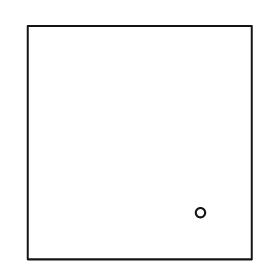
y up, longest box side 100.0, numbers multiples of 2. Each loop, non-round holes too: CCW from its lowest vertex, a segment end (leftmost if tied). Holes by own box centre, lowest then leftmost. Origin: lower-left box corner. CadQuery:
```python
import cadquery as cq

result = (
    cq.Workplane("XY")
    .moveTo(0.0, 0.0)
    .lineTo(96.0, 0.0)
    .lineTo(96.0, 100.0)
    .lineTo(0.0, 100.0)
    .close()
    .moveTo(74.0, 20.0)
    .circle(2.0)
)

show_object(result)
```